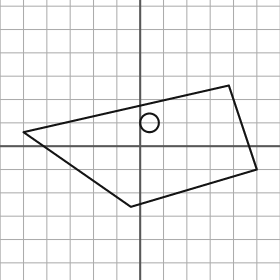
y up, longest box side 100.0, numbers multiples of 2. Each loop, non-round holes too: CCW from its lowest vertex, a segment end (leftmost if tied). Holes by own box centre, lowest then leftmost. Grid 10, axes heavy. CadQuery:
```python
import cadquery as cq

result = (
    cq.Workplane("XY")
    .moveTo(-4.0, -26.0)
    .lineTo(50.0, -10.0)
    .lineTo(38.0, 26.0)
    .lineTo(-50.0, 6.0)
    .close()
    .moveTo(4.0, 10.0)
    .circle(4.0)
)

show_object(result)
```